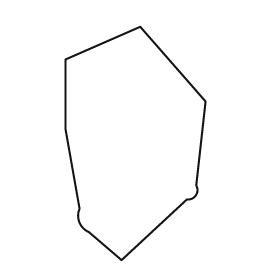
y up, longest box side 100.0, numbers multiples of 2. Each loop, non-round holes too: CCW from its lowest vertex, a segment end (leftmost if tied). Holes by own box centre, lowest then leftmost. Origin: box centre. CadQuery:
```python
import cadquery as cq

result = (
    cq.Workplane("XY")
    .moveTo(-6.0, -50.0)
    .lineTo(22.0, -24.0)
    .threePointArc((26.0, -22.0), (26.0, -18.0))
    .lineTo(30.0, 18.0)
    .lineTo(2.0, 50.0)
    .lineTo(-30.0, 36.0)
    .lineTo(-30.0, 6.0)
    .lineTo(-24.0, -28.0)
    .threePointArc((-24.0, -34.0), (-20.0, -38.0))
    .close()
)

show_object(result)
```